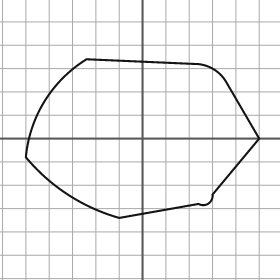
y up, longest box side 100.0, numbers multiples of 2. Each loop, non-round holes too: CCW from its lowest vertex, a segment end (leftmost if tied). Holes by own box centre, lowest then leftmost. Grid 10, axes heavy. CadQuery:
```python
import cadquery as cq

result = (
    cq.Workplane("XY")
    .moveTo(-10.0, -34.0)
    .lineTo(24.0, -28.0)
    .threePointArc((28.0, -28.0), (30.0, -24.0))
    .lineTo(50.0, 0.0)
    .lineTo(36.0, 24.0)
    .threePointArc((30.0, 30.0), (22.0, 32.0))
    .lineTo(-24.0, 34.0)
    .threePointArc((-42.0, 16.0), (-50.0, -8.0))
    .threePointArc((-32.0, -24.0), (-10.0, -34.0))
    .close()
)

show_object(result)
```